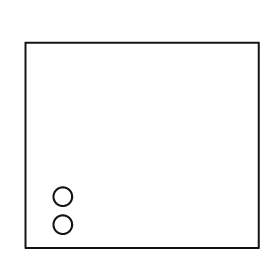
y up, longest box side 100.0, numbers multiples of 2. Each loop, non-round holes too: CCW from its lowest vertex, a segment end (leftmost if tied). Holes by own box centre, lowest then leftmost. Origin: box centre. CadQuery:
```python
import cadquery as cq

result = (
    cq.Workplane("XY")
    .moveTo(-50.0, -44.0)
    .lineTo(50.0, -44.0)
    .lineTo(50.0, 44.0)
    .lineTo(-50.0, 44.0)
    .close()
    .moveTo(-34.0, -34.0)
    .circle(4.0)
    .moveTo(-34.0, -22.0)
    .circle(4.0)
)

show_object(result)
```